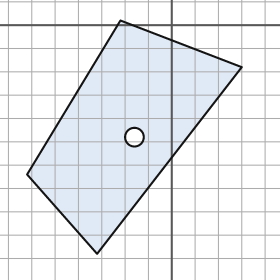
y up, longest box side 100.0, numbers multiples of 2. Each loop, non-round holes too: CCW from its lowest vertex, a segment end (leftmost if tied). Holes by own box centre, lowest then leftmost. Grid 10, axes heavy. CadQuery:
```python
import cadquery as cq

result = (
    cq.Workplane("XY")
    .moveTo(-32.0, -98.0)
    .lineTo(30.0, -18.0)
    .lineTo(-22.0, 2.0)
    .lineTo(-62.0, -64.0)
    .close()
    .moveTo(-16.0, -48.0)
    .circle(4.0)
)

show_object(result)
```